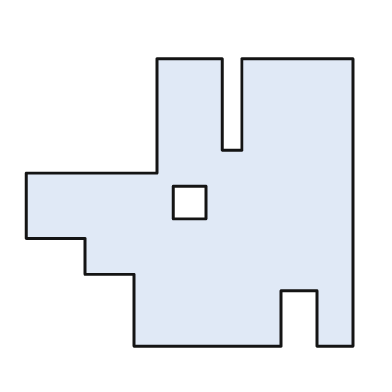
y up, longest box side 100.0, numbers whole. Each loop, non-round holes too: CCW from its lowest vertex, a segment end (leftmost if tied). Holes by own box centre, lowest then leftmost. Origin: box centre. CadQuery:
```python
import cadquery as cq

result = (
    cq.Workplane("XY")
    .moveTo(-17.0, -44.0)
    .lineTo(28.0, -44.0)
    .lineTo(28.0, -27.0)
    .lineTo(39.0, -27.0)
    .lineTo(39.0, -44.0)
    .lineTo(50.0, -44.0)
    .lineTo(50.0, 44.0)
    .lineTo(16.0, 44.0)
    .lineTo(16.0, 16.0)
    .lineTo(10.0, 16.0)
    .lineTo(10.0, 44.0)
    .lineTo(-10.0, 44.0)
    .lineTo(-10.0, 9.0)
    .lineTo(-50.0, 9.0)
    .lineTo(-50.0, -11.0)
    .lineTo(-32.0, -11.0)
    .lineTo(-32.0, -22.0)
    .lineTo(-17.0, -22.0)
    .close()
    .moveTo(-5.0, -5.0)
    .lineTo(5.0, -5.0)
    .lineTo(5.0, 5.0)
    .lineTo(-5.0, 5.0)
    .close()
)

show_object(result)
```